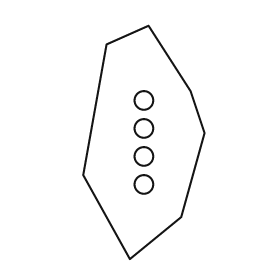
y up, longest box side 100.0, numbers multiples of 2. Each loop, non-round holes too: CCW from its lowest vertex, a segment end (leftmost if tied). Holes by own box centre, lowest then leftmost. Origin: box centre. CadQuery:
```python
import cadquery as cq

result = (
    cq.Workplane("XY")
    .moveTo(-6.0, -50.0)
    .lineTo(16.0, -32.0)
    .lineTo(26.0, 4.0)
    .lineTo(20.0, 22.0)
    .lineTo(2.0, 50.0)
    .lineTo(-16.0, 42.0)
    .lineTo(-26.0, -14.0)
    .close()
    .moveTo(0.0, -18.0)
    .circle(4.0)
    .moveTo(0.0, -6.0)
    .circle(4.0)
    .moveTo(0.0, 6.0)
    .circle(4.0)
    .moveTo(0.0, 18.0)
    .circle(4.0)
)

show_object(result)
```